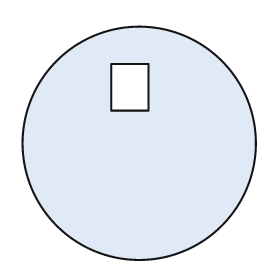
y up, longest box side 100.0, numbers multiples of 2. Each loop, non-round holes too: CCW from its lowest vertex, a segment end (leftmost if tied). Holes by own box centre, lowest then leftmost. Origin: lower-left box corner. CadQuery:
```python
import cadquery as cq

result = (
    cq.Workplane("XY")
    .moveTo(50.0, 50.0)
    .circle(50.0)
    .moveTo(38.0, 64.0)
    .lineTo(54.0, 64.0)
    .lineTo(54.0, 84.0)
    .lineTo(38.0, 84.0)
    .close()
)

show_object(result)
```